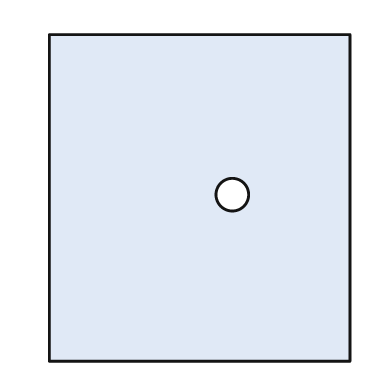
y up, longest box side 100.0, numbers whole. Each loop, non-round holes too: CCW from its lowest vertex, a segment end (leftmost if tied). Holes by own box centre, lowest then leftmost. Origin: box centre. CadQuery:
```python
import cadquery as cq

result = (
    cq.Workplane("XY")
    .moveTo(-46.0, -50.0)
    .lineTo(46.0, -50.0)
    .lineTo(46.0, 50.0)
    .lineTo(-46.0, 50.0)
    .close()
    .moveTo(10.0, 1.0)
    .circle(5.0)
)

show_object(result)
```